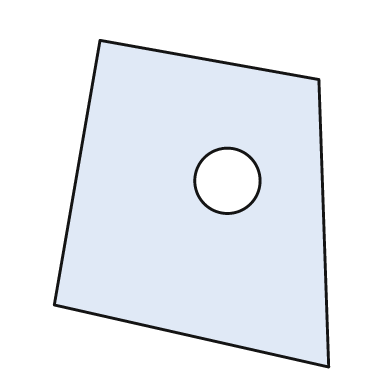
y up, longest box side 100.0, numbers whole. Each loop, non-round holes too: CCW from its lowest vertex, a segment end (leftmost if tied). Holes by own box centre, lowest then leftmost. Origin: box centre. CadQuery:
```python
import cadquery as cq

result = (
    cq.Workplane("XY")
    .moveTo(42.0, -50.0)
    .lineTo(39.0, 38.0)
    .lineTo(-28.0, 50.0)
    .lineTo(-42.0, -31.0)
    .close()
    .moveTo(11.0, 7.0)
    .circle(10.0)
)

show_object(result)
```